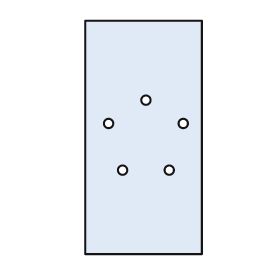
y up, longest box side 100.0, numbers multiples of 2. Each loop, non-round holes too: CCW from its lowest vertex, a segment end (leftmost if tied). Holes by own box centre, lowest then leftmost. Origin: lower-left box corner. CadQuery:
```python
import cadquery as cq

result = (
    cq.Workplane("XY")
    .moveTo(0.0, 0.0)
    .lineTo(50.0, 0.0)
    .lineTo(50.0, 100.0)
    .lineTo(0.0, 100.0)
    .close()
    .moveTo(16.0, 36.0)
    .circle(2.0)
    .moveTo(36.0, 36.0)
    .circle(2.0)
    .moveTo(10.0, 56.0)
    .circle(2.0)
    .moveTo(42.0, 56.0)
    .circle(2.0)
    .moveTo(26.0, 66.0)
    .circle(2.0)
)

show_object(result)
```